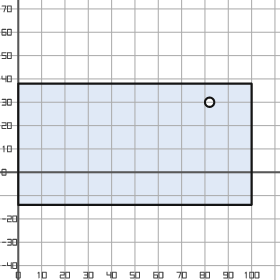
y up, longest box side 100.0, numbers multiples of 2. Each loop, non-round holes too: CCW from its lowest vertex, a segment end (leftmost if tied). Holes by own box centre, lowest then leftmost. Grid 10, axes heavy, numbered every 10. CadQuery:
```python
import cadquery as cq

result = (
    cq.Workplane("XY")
    .moveTo(0.0, -14.0)
    .lineTo(100.0, -14.0)
    .lineTo(100.0, 38.0)
    .lineTo(0.0, 38.0)
    .close()
    .moveTo(82.0, 30.0)
    .circle(2.0)
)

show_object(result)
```